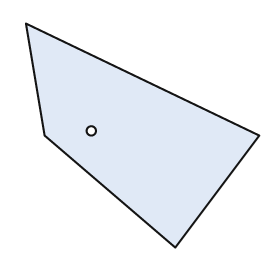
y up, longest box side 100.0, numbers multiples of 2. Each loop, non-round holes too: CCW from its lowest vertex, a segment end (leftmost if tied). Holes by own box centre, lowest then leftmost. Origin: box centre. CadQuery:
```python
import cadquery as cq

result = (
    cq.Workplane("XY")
    .moveTo(14.0, -48.0)
    .lineTo(50.0, 0.0)
    .lineTo(-50.0, 48.0)
    .lineTo(-42.0, 0.0)
    .close()
    .moveTo(-22.0, 2.0)
    .circle(2.0)
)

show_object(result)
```